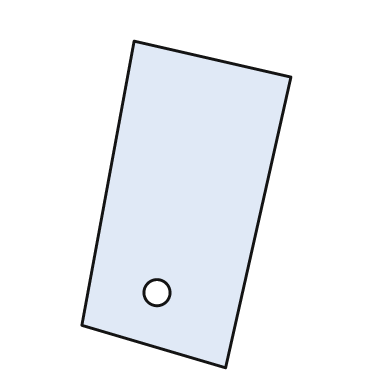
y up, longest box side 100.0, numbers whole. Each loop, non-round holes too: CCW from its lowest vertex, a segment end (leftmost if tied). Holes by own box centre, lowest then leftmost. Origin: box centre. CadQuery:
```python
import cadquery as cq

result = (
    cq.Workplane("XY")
    .moveTo(12.0, -50.0)
    .lineTo(32.0, 39.0)
    .lineTo(-16.0, 50.0)
    .lineTo(-32.0, -37.0)
    .close()
    .moveTo(-9.0, -27.0)
    .circle(4.0)
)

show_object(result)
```